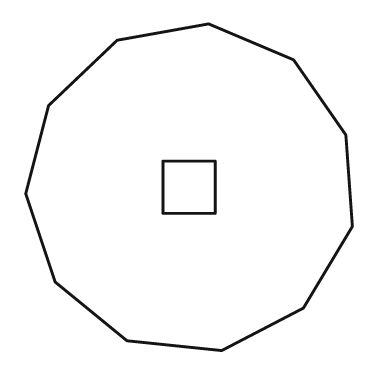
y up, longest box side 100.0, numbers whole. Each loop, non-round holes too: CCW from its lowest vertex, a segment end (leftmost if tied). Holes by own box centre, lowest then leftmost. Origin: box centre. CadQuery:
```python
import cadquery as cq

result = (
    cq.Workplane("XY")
    .moveTo(10.0, -50.0)
    .lineTo(35.0, -37.0)
    .lineTo(50.0, -12.0)
    .lineTo(48.0, 16.0)
    .lineTo(32.0, 39.0)
    .lineTo(6.0, 50.0)
    .lineTo(-22.0, 45.0)
    .lineTo(-43.0, 25.0)
    .lineTo(-50.0, -2.0)
    .lineTo(-41.0, -29.0)
    .lineTo(-19.0, -47.0)
    .close()
    .moveTo(-8.0, -8.0)
    .lineTo(8.0, -8.0)
    .lineTo(8.0, 8.0)
    .lineTo(-8.0, 8.0)
    .close()
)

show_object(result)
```